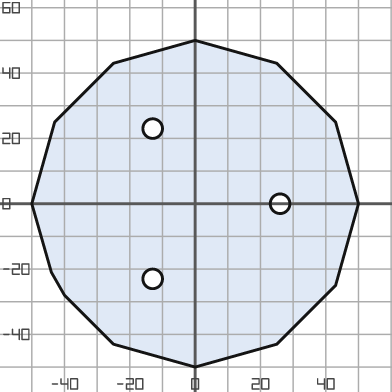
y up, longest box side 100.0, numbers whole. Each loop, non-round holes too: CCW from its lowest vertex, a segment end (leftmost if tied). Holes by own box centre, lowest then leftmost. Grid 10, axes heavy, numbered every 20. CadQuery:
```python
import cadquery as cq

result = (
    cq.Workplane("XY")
    .moveTo(0.0, -50.0)
    .lineTo(25.0, -43.0)
    .lineTo(43.0, -25.0)
    .lineTo(50.0, 0.0)
    .lineTo(43.0, 25.0)
    .lineTo(25.0, 43.0)
    .lineTo(0.0, 50.0)
    .lineTo(-25.0, 43.0)
    .lineTo(-43.0, 25.0)
    .lineTo(-50.0, 0.0)
    .lineTo(-44.0, -21.0)
    .lineTo(-40.0, -28.0)
    .lineTo(-25.0, -43.0)
    .close()
    .moveTo(-13.0, -23.0)
    .circle(3.0)
    .moveTo(26.0, 0.0)
    .circle(3.0)
    .moveTo(-13.0, 23.0)
    .circle(3.0)
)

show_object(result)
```